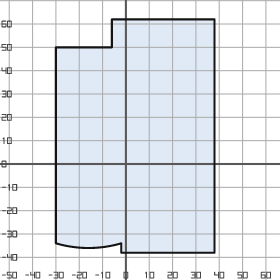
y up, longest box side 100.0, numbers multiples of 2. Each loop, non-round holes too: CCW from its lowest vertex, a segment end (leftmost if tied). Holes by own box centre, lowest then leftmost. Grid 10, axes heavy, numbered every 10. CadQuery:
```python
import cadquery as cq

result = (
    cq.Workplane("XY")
    .moveTo(-2.0, -38.0)
    .lineTo(38.0, -38.0)
    .lineTo(38.0, 62.0)
    .lineTo(-6.0, 62.0)
    .lineTo(-6.0, 50.0)
    .lineTo(-30.0, 50.0)
    .lineTo(-30.0, -34.0)
    .threePointArc((-16.0, -36.0), (-2.0, -34.0))
    .close()
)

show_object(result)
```